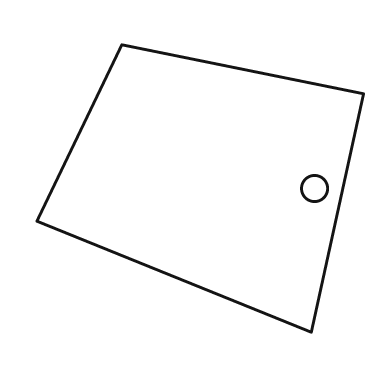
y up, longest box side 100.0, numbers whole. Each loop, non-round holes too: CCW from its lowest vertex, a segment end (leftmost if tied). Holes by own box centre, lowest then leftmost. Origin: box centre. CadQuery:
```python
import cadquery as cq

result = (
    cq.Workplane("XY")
    .moveTo(34.0, -44.0)
    .lineTo(50.0, 29.0)
    .lineTo(-24.0, 44.0)
    .lineTo(-50.0, -10.0)
    .close()
    .moveTo(35.0, 0.0)
    .circle(4.0)
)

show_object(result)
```